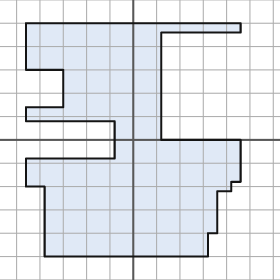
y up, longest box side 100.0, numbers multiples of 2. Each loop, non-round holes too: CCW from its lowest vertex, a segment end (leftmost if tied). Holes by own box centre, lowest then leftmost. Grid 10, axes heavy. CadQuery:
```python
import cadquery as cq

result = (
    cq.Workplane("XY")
    .moveTo(-38.0, -50.0)
    .lineTo(32.0, -50.0)
    .lineTo(32.0, -40.0)
    .lineTo(36.0, -40.0)
    .lineTo(36.0, -22.0)
    .lineTo(42.0, -22.0)
    .lineTo(42.0, -18.0)
    .lineTo(46.0, -18.0)
    .lineTo(46.0, 0.0)
    .lineTo(12.0, 0.0)
    .lineTo(12.0, 46.0)
    .lineTo(46.0, 46.0)
    .lineTo(46.0, 50.0)
    .lineTo(-46.0, 50.0)
    .lineTo(-46.0, 30.0)
    .lineTo(-30.0, 30.0)
    .lineTo(-30.0, 14.0)
    .lineTo(-46.0, 14.0)
    .lineTo(-46.0, 8.0)
    .lineTo(-8.0, 8.0)
    .lineTo(-8.0, -8.0)
    .lineTo(-46.0, -8.0)
    .lineTo(-46.0, -20.0)
    .lineTo(-38.0, -20.0)
    .close()
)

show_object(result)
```